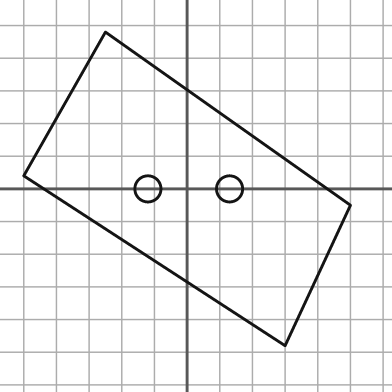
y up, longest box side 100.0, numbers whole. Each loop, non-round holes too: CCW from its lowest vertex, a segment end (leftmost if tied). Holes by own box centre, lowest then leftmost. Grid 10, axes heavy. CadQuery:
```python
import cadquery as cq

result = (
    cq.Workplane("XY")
    .moveTo(30.0, -48.0)
    .lineTo(50.0, -5.0)
    .lineTo(-25.0, 48.0)
    .lineTo(-50.0, 4.0)
    .close()
    .moveTo(-12.0, 0.0)
    .circle(4.0)
    .moveTo(13.0, 0.0)
    .circle(4.0)
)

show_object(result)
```